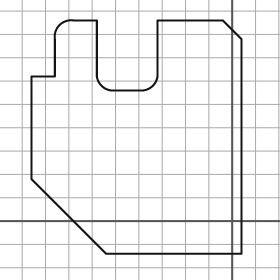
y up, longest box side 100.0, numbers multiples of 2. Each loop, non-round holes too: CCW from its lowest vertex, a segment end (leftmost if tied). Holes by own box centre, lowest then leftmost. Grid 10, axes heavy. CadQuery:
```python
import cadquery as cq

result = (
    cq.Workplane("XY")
    .moveTo(-54.0, -14.0)
    .lineTo(4.0, -14.0)
    .lineTo(4.0, 78.0)
    .lineTo(-4.0, 86.0)
    .lineTo(-32.0, 86.0)
    .lineTo(-32.0, 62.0)
    .threePointArc((-34.0, 58.0), (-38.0, 56.0))
    .lineTo(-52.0, 56.0)
    .threePointArc((-56.0, 58.0), (-58.0, 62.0))
    .lineTo(-58.0, 86.0)
    .lineTo(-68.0, 86.0)
    .threePointArc((-74.0, 84.0), (-76.0, 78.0))
    .lineTo(-76.0, 62.0)
    .lineTo(-86.0, 62.0)
    .lineTo(-86.0, 18.0)
    .close()
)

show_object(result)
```